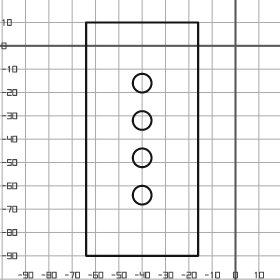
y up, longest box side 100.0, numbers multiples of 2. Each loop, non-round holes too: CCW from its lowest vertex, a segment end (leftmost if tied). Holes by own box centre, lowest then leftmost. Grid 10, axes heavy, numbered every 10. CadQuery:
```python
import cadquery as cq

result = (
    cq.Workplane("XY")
    .moveTo(-64.0, -90.0)
    .lineTo(-16.0, -90.0)
    .lineTo(-16.0, 10.0)
    .lineTo(-64.0, 10.0)
    .close()
    .moveTo(-40.0, -64.0)
    .circle(4.0)
    .moveTo(-40.0, -48.0)
    .circle(4.0)
    .moveTo(-40.0, -32.0)
    .circle(4.0)
    .moveTo(-40.0, -16.0)
    .circle(4.0)
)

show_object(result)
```